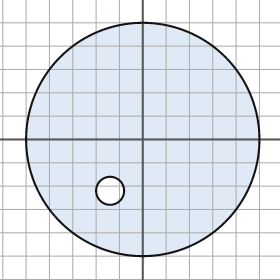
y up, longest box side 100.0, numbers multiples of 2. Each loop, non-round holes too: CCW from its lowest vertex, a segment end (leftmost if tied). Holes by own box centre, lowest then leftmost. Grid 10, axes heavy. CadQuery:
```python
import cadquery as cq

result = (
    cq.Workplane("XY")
    .moveTo(0.0, 0.0)
    .circle(50.0)
    .moveTo(-14.0, -22.0)
    .circle(6.0)
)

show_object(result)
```